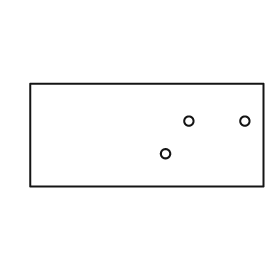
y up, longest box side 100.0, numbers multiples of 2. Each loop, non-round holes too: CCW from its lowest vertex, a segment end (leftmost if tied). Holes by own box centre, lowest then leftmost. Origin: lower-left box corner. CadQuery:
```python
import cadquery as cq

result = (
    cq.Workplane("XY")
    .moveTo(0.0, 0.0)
    .lineTo(100.0, 0.0)
    .lineTo(100.0, 44.0)
    .lineTo(0.0, 44.0)
    .close()
    .moveTo(58.0, 14.0)
    .circle(2.0)
    .moveTo(68.0, 28.0)
    .circle(2.0)
    .moveTo(92.0, 28.0)
    .circle(2.0)
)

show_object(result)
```